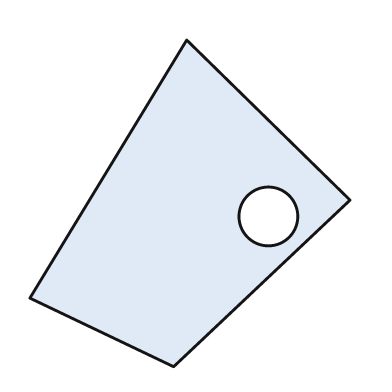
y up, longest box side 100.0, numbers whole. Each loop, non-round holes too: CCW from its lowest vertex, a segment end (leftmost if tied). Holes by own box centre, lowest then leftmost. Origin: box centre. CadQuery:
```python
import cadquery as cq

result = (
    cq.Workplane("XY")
    .moveTo(-5.0, -50.0)
    .lineTo(49.0, 1.0)
    .lineTo(-1.0, 50.0)
    .lineTo(-49.0, -29.0)
    .close()
    .moveTo(24.0, -4.0)
    .circle(9.0)
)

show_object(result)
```